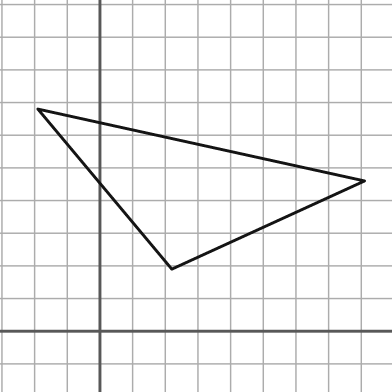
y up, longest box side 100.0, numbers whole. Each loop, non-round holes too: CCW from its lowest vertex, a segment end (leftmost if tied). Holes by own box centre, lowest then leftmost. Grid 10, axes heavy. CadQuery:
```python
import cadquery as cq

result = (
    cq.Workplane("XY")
    .moveTo(22.0, 19.0)
    .lineTo(81.0, 46.0)
    .lineTo(-19.0, 68.0)
    .close()
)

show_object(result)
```